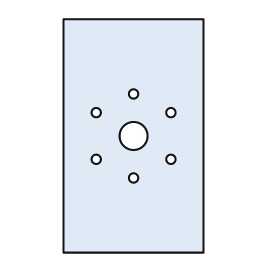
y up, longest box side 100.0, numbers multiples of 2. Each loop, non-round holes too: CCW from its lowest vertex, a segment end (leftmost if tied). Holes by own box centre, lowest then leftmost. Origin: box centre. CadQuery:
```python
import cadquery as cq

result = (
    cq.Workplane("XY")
    .moveTo(-30.0, -50.0)
    .lineTo(30.0, -50.0)
    .lineTo(30.0, 50.0)
    .lineTo(-30.0, 50.0)
    .close()
    .moveTo(0.0, -18.0)
    .circle(2.0)
    .moveTo(-16.0, -10.0)
    .circle(2.0)
    .moveTo(16.0, -10.0)
    .circle(2.0)
    .moveTo(0.0, 0.0)
    .circle(6.0)
    .moveTo(-16.0, 10.0)
    .circle(2.0)
    .moveTo(16.0, 10.0)
    .circle(2.0)
    .moveTo(0.0, 18.0)
    .circle(2.0)
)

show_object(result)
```